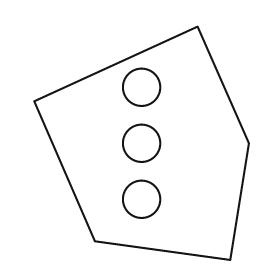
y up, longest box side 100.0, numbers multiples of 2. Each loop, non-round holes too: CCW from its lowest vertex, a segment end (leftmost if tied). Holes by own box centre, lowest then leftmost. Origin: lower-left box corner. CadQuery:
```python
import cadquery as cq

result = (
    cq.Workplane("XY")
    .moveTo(84.0, 0.0)
    .lineTo(92.0, 50.0)
    .lineTo(70.0, 100.0)
    .lineTo(0.0, 68.0)
    .lineTo(26.0, 8.0)
    .close()
    .moveTo(46.0, 26.0)
    .circle(8.0)
    .moveTo(46.0, 50.0)
    .circle(8.0)
    .moveTo(46.0, 74.0)
    .circle(8.0)
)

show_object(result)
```